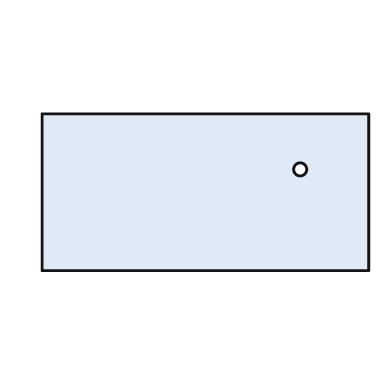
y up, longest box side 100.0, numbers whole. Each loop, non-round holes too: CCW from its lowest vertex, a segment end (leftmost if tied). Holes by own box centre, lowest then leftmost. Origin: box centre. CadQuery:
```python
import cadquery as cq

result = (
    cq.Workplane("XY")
    .moveTo(-50.0, -24.0)
    .lineTo(50.0, -24.0)
    .lineTo(50.0, 24.0)
    .lineTo(-50.0, 24.0)
    .close()
    .moveTo(29.0, 7.0)
    .circle(2.0)
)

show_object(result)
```